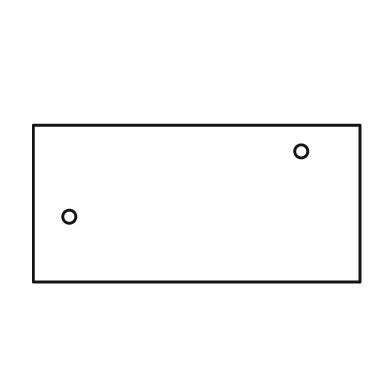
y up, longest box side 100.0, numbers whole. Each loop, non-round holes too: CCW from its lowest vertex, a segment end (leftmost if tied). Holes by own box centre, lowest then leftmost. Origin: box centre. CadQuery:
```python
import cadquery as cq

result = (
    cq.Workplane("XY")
    .moveTo(-50.0, -24.0)
    .lineTo(50.0, -24.0)
    .lineTo(50.0, 24.0)
    .lineTo(-50.0, 24.0)
    .close()
    .moveTo(-39.0, -4.0)
    .circle(2.0)
    .moveTo(32.0, 16.0)
    .circle(2.0)
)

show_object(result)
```